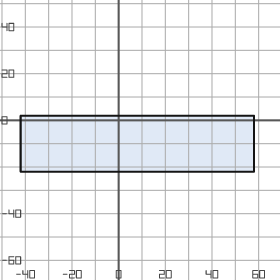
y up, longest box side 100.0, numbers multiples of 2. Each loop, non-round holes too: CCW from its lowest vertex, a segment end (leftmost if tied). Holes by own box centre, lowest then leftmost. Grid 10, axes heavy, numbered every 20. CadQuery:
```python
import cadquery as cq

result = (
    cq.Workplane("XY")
    .moveTo(-42.0, -22.0)
    .lineTo(58.0, -22.0)
    .lineTo(58.0, 2.0)
    .lineTo(-42.0, 2.0)
    .close()
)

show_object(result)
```